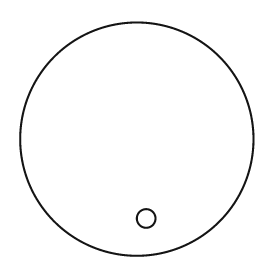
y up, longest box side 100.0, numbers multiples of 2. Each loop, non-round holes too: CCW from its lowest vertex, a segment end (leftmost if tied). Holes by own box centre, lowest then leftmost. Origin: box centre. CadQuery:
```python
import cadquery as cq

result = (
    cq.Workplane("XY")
    .moveTo(0.0, 0.0)
    .circle(50.0)
    .moveTo(4.0, -34.0)
    .circle(4.0)
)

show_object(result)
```